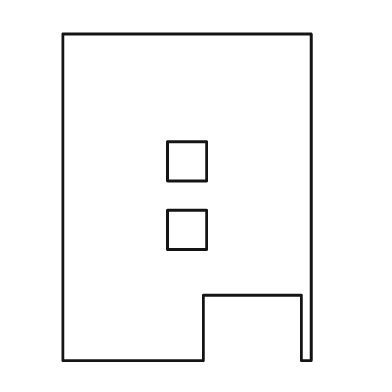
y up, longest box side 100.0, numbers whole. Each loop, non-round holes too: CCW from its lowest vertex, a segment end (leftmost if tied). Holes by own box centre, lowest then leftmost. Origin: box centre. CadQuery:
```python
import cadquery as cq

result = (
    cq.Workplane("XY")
    .moveTo(-38.0, -50.0)
    .lineTo(5.0, -50.0)
    .lineTo(5.0, -30.0)
    .lineTo(35.0, -30.0)
    .lineTo(35.0, -50.0)
    .lineTo(38.0, -50.0)
    .lineTo(38.0, 50.0)
    .lineTo(-38.0, 50.0)
    .close()
    .moveTo(-6.0, -16.0)
    .lineTo(6.0, -16.0)
    .lineTo(6.0, -4.0)
    .lineTo(-6.0, -4.0)
    .close()
    .moveTo(-6.0, 5.0)
    .lineTo(6.0, 5.0)
    .lineTo(6.0, 17.0)
    .lineTo(-6.0, 17.0)
    .close()
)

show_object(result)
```